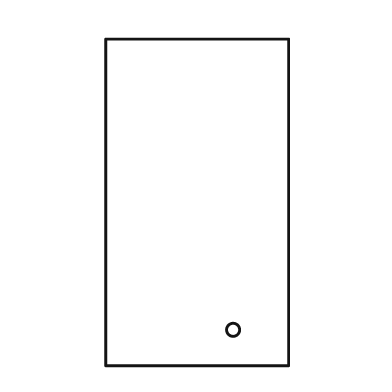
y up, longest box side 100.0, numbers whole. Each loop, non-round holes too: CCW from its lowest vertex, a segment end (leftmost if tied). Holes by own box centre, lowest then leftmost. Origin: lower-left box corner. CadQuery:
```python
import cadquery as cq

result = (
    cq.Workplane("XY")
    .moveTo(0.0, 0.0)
    .lineTo(56.0, 0.0)
    .lineTo(56.0, 100.0)
    .lineTo(0.0, 100.0)
    .close()
    .moveTo(39.0, 11.0)
    .circle(2.0)
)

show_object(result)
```